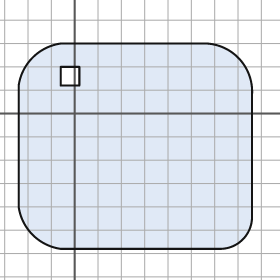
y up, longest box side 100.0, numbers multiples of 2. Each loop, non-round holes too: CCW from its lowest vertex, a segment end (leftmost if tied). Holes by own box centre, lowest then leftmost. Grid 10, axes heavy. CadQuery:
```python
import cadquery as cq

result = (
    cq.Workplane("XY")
    .moveTo(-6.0, -58.0)
    .lineTo(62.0, -58.0)
    .threePointArc((72.0, -54.0), (76.0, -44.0))
    .lineTo(76.0, 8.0)
    .threePointArc((70.0, 24.0), (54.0, 30.0))
    .lineTo(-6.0, 30.0)
    .threePointArc((-18.0, 24.0), (-24.0, 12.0))
    .lineTo(-24.0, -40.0)
    .threePointArc((-18.0, -52.0), (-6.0, -58.0))
    .close()
    .moveTo(-6.0, 12.0)
    .lineTo(2.0, 12.0)
    .lineTo(2.0, 20.0)
    .lineTo(-6.0, 20.0)
    .close()
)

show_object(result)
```